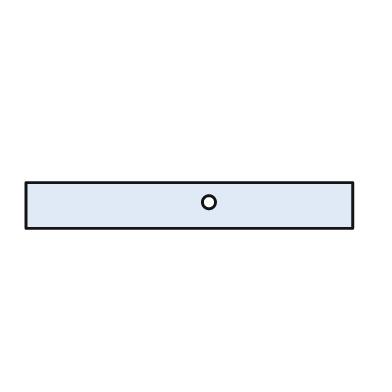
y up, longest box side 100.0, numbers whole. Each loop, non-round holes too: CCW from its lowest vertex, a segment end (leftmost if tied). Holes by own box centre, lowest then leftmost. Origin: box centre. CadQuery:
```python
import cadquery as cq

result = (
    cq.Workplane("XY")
    .moveTo(-50.0, -7.0)
    .lineTo(50.0, -7.0)
    .lineTo(50.0, 7.0)
    .lineTo(-50.0, 7.0)
    .close()
    .moveTo(6.0, 1.0)
    .circle(2.0)
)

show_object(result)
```